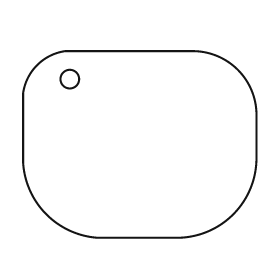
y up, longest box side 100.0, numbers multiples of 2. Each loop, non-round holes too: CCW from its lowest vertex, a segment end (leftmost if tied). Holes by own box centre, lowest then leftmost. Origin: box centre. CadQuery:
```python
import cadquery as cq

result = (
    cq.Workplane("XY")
    .moveTo(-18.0, -40.0)
    .lineTo(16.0, -40.0)
    .threePointArc((40.0, -30.0), (50.0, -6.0))
    .lineTo(50.0, 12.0)
    .threePointArc((42.0, 32.0), (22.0, 40.0))
    .lineTo(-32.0, 40.0)
    .threePointArc((-44.0, 34.0), (-50.0, 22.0))
    .lineTo(-50.0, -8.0)
    .threePointArc((-40.0, -30.0), (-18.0, -40.0))
    .close()
    .moveTo(-30.0, 28.0)
    .circle(4.0)
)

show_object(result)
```